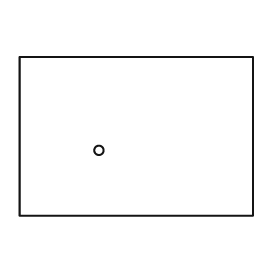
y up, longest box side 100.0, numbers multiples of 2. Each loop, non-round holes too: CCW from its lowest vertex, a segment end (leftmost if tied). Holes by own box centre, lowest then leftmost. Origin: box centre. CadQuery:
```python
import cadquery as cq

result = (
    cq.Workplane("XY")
    .moveTo(-50.0, -34.0)
    .lineTo(50.0, -34.0)
    .lineTo(50.0, 34.0)
    .lineTo(-50.0, 34.0)
    .close()
    .moveTo(-16.0, -6.0)
    .circle(2.0)
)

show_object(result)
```